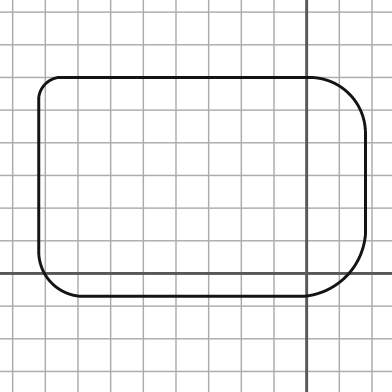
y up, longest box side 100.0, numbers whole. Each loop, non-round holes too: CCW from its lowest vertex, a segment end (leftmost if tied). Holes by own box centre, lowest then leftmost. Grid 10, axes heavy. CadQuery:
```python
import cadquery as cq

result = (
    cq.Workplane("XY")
    .moveTo(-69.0, -7.0)
    .lineTo(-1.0, -7.0)
    .threePointArc((12.0, -1.0), (18.0, 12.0))
    .lineTo(18.0, 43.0)
    .threePointArc((13.0, 55.0), (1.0, 60.0))
    .lineTo(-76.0, 60.0)
    .threePointArc((-80.0, 58.0), (-82.0, 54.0))
    .lineTo(-82.0, 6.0)
    .threePointArc((-78.0, -3.0), (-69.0, -7.0))
    .close()
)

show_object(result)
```